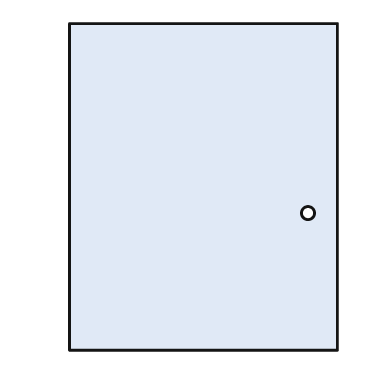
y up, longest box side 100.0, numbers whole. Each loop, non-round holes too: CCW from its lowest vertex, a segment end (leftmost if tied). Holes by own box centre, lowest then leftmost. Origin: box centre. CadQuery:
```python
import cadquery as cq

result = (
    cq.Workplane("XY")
    .moveTo(-41.0, -50.0)
    .lineTo(41.0, -50.0)
    .lineTo(41.0, 50.0)
    .lineTo(-41.0, 50.0)
    .close()
    .moveTo(32.0, -8.0)
    .circle(2.0)
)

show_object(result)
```